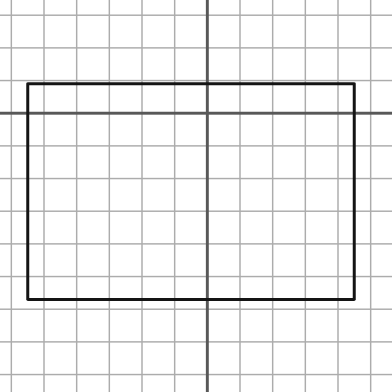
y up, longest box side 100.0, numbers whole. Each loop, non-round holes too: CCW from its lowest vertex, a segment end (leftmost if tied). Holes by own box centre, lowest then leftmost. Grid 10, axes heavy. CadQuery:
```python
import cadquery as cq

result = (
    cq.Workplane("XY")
    .moveTo(-55.0, -57.0)
    .lineTo(45.0, -57.0)
    .lineTo(45.0, 9.0)
    .lineTo(-55.0, 9.0)
    .close()
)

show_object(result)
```